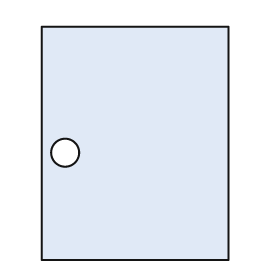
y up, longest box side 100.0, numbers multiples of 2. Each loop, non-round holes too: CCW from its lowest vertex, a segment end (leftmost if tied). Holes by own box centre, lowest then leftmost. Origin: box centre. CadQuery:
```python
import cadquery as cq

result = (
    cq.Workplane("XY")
    .moveTo(-40.0, -50.0)
    .lineTo(40.0, -50.0)
    .lineTo(40.0, 50.0)
    .lineTo(-40.0, 50.0)
    .close()
    .moveTo(-30.0, -4.0)
    .circle(6.0)
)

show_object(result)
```